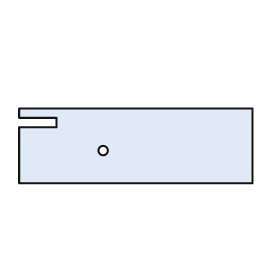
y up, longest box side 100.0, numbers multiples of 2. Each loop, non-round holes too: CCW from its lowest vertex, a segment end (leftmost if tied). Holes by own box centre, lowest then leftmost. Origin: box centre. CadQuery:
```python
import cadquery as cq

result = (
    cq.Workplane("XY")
    .moveTo(-50.0, -16.0)
    .lineTo(50.0, -16.0)
    .lineTo(50.0, 16.0)
    .lineTo(-50.0, 16.0)
    .lineTo(-50.0, 12.0)
    .lineTo(-34.0, 12.0)
    .lineTo(-34.0, 8.0)
    .lineTo(-50.0, 8.0)
    .close()
    .moveTo(-14.0, -2.0)
    .circle(2.0)
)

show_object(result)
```